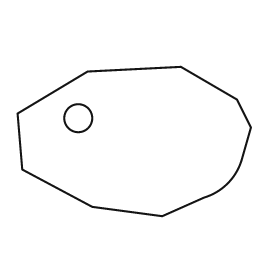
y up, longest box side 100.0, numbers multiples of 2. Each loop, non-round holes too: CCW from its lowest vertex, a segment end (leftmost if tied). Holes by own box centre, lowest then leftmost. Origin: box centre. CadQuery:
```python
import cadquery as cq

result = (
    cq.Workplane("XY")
    .moveTo(12.0, -32.0)
    .lineTo(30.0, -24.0)
    .threePointArc((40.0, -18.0), (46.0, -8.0))
    .lineTo(50.0, 6.0)
    .lineTo(44.0, 18.0)
    .lineTo(20.0, 32.0)
    .lineTo(-20.0, 30.0)
    .lineTo(-50.0, 12.0)
    .lineTo(-48.0, -12.0)
    .lineTo(-18.0, -28.0)
    .close()
    .moveTo(-24.0, 10.0)
    .circle(6.0)
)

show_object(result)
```